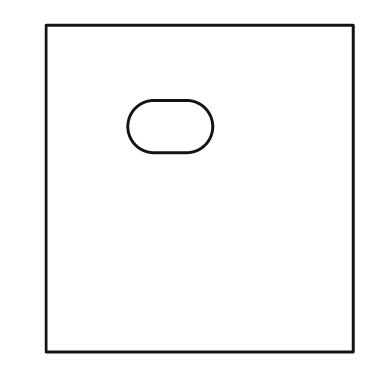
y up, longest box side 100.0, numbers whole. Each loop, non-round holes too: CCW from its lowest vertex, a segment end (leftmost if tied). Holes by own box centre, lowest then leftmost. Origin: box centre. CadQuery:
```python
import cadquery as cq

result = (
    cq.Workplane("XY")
    .moveTo(-47.0, -50.0)
    .lineTo(47.0, -50.0)
    .lineTo(47.0, 50.0)
    .lineTo(-47.0, 50.0)
    .close()
    .moveTo(-14.0, 11.0)
    .lineTo(-4.0, 11.0)
    .threePointArc((4.0, 19.0), (-4.0, 27.0))
    .lineTo(-14.0, 27.0)
    .threePointArc((-22.0, 19.0), (-14.0, 11.0))
    .close()
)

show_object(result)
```